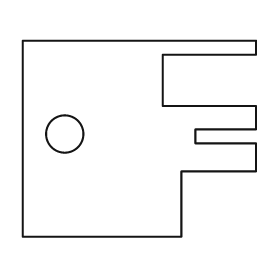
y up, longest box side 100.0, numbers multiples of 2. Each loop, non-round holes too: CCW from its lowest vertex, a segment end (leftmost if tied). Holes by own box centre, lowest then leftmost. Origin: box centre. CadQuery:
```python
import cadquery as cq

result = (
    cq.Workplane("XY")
    .moveTo(-50.0, -42.0)
    .lineTo(18.0, -42.0)
    .lineTo(18.0, -14.0)
    .lineTo(50.0, -14.0)
    .lineTo(50.0, -2.0)
    .lineTo(24.0, -2.0)
    .lineTo(24.0, 4.0)
    .lineTo(50.0, 4.0)
    .lineTo(50.0, 14.0)
    .lineTo(10.0, 14.0)
    .lineTo(10.0, 36.0)
    .lineTo(50.0, 36.0)
    .lineTo(50.0, 42.0)
    .lineTo(-50.0, 42.0)
    .close()
    .moveTo(-32.0, 2.0)
    .circle(8.0)
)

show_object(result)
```